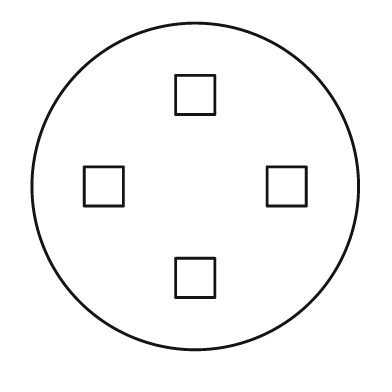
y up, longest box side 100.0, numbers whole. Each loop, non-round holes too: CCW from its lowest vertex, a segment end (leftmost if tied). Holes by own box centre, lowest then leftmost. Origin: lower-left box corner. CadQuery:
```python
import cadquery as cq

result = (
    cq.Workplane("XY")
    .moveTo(50.0, 50.0)
    .circle(50.0)
    .moveTo(44.0, 16.0)
    .lineTo(56.0, 16.0)
    .lineTo(56.0, 28.0)
    .lineTo(44.0, 28.0)
    .close()
    .moveTo(16.0, 44.0)
    .lineTo(28.0, 44.0)
    .lineTo(28.0, 56.0)
    .lineTo(16.0, 56.0)
    .close()
    .moveTo(72.0, 44.0)
    .lineTo(84.0, 44.0)
    .lineTo(84.0, 56.0)
    .lineTo(72.0, 56.0)
    .close()
    .moveTo(44.0, 72.0)
    .lineTo(56.0, 72.0)
    .lineTo(56.0, 84.0)
    .lineTo(44.0, 84.0)
    .close()
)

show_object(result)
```